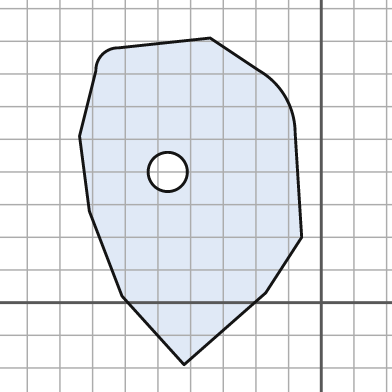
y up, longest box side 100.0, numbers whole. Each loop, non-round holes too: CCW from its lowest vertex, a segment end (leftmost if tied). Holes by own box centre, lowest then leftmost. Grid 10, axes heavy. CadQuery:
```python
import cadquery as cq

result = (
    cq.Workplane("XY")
    .moveTo(-42.0, -19.0)
    .lineTo(-17.0, 3.0)
    .lineTo(-6.0, 20.0)
    .lineTo(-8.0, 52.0)
    .threePointArc((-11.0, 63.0), (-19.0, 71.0))
    .lineTo(-34.0, 81.0)
    .lineTo(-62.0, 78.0)
    .threePointArc((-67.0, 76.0), (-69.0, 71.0))
    .lineTo(-74.0, 51.0)
    .lineTo(-71.0, 28.0)
    .lineTo(-61.0, 2.0)
    .close()
    .moveTo(-47.0, 40.0)
    .circle(6.0)
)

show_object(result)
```